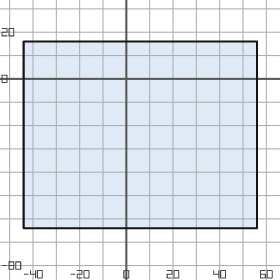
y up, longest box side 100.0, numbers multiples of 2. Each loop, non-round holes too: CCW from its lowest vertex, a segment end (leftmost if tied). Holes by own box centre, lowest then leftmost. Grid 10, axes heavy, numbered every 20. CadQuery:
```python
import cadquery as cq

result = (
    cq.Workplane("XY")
    .moveTo(-44.0, -64.0)
    .lineTo(56.0, -64.0)
    .lineTo(56.0, 16.0)
    .lineTo(-44.0, 16.0)
    .close()
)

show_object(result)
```